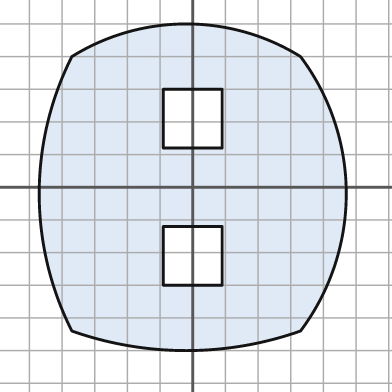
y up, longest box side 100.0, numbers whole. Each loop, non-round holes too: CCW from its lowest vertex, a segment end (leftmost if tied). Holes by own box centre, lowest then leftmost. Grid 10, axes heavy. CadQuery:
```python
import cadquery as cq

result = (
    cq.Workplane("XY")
    .moveTo(-37.0, -44.0)
    .threePointArc((-2.0, -50.0), (33.0, -44.0))
    .threePointArc((47.0, -2.0), (33.0, 40.0))
    .threePointArc((-2.0, 50.0), (-37.0, 40.0))
    .threePointArc((-47.0, -2.0), (-37.0, -44.0))
    .close()
    .moveTo(-9.0, -30.0)
    .lineTo(9.0, -30.0)
    .lineTo(9.0, -12.0)
    .lineTo(-9.0, -12.0)
    .close()
    .moveTo(-9.0, 12.0)
    .lineTo(9.0, 12.0)
    .lineTo(9.0, 30.0)
    .lineTo(-9.0, 30.0)
    .close()
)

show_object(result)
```